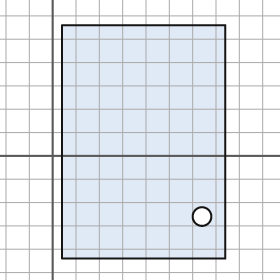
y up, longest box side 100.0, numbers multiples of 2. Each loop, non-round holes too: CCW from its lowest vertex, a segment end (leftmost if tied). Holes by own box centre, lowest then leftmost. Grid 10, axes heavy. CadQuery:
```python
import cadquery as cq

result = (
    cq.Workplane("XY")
    .moveTo(4.0, -44.0)
    .lineTo(74.0, -44.0)
    .lineTo(74.0, 56.0)
    .lineTo(4.0, 56.0)
    .close()
    .moveTo(64.0, -26.0)
    .circle(4.0)
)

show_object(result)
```